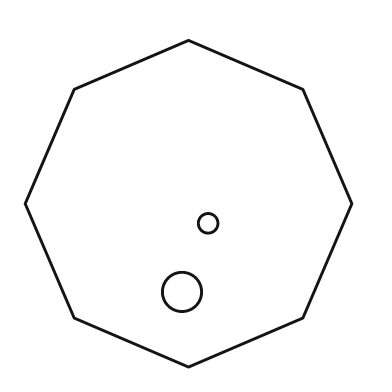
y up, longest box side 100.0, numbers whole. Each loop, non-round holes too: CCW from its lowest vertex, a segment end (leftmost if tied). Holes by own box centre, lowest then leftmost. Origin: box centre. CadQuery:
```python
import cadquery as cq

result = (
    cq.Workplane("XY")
    .moveTo(0.0, -50.0)
    .lineTo(35.0, -35.0)
    .lineTo(50.0, 0.0)
    .lineTo(35.0, 35.0)
    .lineTo(0.0, 50.0)
    .lineTo(-35.0, 35.0)
    .lineTo(-50.0, 0.0)
    .lineTo(-35.0, -35.0)
    .close()
    .moveTo(-2.0, -27.0)
    .circle(6.0)
    .moveTo(6.0, -6.0)
    .circle(3.0)
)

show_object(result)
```